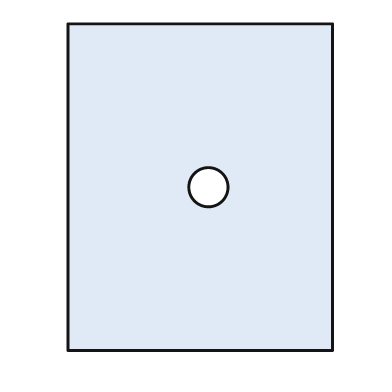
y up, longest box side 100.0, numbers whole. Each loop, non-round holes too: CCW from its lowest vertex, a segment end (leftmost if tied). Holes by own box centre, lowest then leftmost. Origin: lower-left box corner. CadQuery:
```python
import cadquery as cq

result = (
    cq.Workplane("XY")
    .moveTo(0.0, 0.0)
    .lineTo(81.0, 0.0)
    .lineTo(81.0, 100.0)
    .lineTo(0.0, 100.0)
    .close()
    .moveTo(43.0, 50.0)
    .circle(6.0)
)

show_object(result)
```